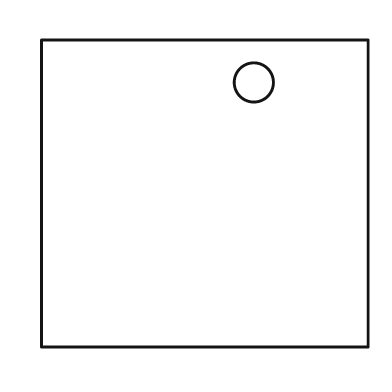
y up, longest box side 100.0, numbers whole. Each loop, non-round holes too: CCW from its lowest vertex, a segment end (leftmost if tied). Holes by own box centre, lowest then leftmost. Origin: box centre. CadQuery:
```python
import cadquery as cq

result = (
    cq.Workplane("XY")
    .moveTo(-50.0, -47.0)
    .lineTo(50.0, -47.0)
    .lineTo(50.0, 47.0)
    .lineTo(-50.0, 47.0)
    .close()
    .moveTo(15.0, 34.0)
    .circle(6.0)
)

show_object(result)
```